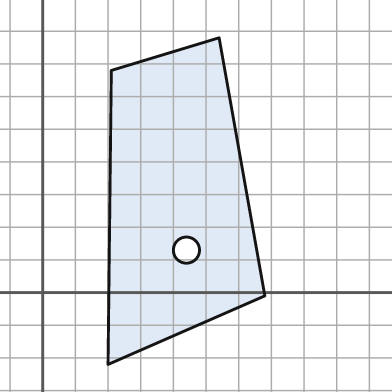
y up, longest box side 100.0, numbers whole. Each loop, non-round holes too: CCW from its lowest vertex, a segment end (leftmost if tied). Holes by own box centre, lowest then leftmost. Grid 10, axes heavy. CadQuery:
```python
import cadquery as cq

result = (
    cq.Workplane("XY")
    .moveTo(20.0, -22.0)
    .lineTo(68.0, -1.0)
    .lineTo(54.0, 78.0)
    .lineTo(21.0, 68.0)
    .close()
    .moveTo(44.0, 13.0)
    .circle(4.0)
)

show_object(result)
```